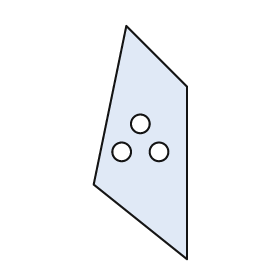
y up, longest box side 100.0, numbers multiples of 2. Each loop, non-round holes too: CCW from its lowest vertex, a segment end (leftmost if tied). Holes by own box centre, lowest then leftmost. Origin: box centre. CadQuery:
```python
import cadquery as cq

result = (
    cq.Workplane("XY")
    .moveTo(20.0, -50.0)
    .lineTo(20.0, 24.0)
    .lineTo(-6.0, 50.0)
    .lineTo(-20.0, -18.0)
    .close()
    .moveTo(-8.0, -4.0)
    .circle(4.0)
    .moveTo(8.0, -4.0)
    .circle(4.0)
    .moveTo(0.0, 8.0)
    .circle(4.0)
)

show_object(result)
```